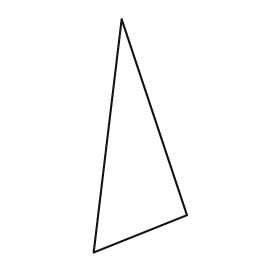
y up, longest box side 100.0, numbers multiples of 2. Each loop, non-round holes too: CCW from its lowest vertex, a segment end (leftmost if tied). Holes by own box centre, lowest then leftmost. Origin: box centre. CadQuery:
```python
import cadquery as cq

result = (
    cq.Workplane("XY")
    .moveTo(-20.0, -50.0)
    .lineTo(20.0, -34.0)
    .lineTo(-8.0, 50.0)
    .close()
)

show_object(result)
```